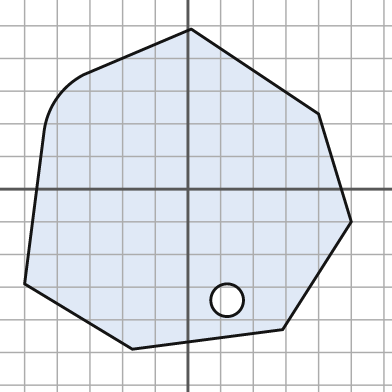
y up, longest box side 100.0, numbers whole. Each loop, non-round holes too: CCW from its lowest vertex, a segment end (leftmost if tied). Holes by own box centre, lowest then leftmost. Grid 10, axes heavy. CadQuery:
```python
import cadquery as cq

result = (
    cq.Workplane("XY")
    .moveTo(-17.0, -49.0)
    .lineTo(29.0, -43.0)
    .lineTo(50.0, -10.0)
    .lineTo(40.0, 23.0)
    .lineTo(1.0, 49.0)
    .lineTo(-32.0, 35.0)
    .threePointArc((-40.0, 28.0), (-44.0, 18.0))
    .lineTo(-50.0, -29.0)
    .close()
    .moveTo(12.0, -34.0)
    .circle(5.0)
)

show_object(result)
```